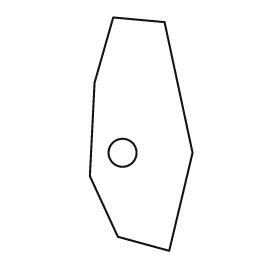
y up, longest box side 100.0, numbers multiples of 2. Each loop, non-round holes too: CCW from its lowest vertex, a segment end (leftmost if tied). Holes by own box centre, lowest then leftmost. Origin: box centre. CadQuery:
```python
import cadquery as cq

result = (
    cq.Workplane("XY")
    .moveTo(12.0, -50.0)
    .lineTo(22.0, -8.0)
    .lineTo(10.0, 48.0)
    .lineTo(-12.0, 50.0)
    .lineTo(-20.0, 22.0)
    .lineTo(-22.0, -18.0)
    .lineTo(-10.0, -44.0)
    .close()
    .moveTo(-8.0, -8.0)
    .circle(6.0)
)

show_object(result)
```